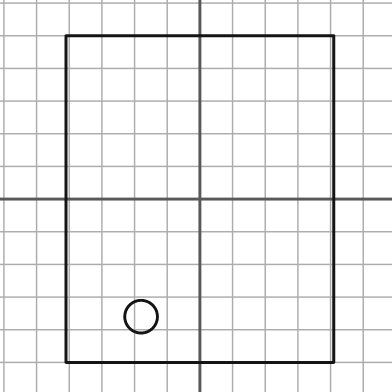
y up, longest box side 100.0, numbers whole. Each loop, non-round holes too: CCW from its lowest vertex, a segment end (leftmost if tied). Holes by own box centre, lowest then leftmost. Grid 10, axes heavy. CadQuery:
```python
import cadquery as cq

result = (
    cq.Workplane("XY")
    .moveTo(-41.0, -50.0)
    .lineTo(41.0, -50.0)
    .lineTo(41.0, 50.0)
    .lineTo(-41.0, 50.0)
    .close()
    .moveTo(-18.0, -36.0)
    .circle(5.0)
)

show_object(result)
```